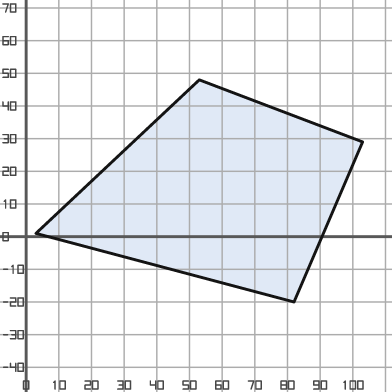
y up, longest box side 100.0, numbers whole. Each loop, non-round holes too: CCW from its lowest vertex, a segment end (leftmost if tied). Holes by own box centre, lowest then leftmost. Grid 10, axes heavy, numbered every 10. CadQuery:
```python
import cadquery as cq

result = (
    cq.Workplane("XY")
    .moveTo(82.0, -20.0)
    .lineTo(103.0, 29.0)
    .lineTo(53.0, 48.0)
    .lineTo(3.0, 1.0)
    .close()
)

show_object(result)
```